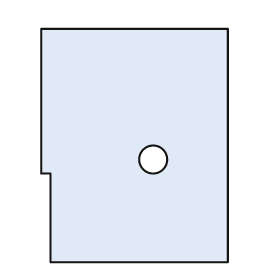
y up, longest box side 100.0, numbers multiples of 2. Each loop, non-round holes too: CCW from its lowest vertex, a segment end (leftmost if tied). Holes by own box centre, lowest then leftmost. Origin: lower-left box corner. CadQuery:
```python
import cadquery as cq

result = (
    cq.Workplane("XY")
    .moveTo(4.0, 0.0)
    .lineTo(80.0, 0.0)
    .lineTo(80.0, 100.0)
    .lineTo(0.0, 100.0)
    .lineTo(0.0, 38.0)
    .lineTo(4.0, 38.0)
    .close()
    .moveTo(48.0, 44.0)
    .circle(6.0)
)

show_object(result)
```